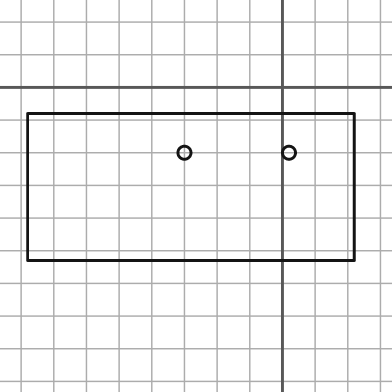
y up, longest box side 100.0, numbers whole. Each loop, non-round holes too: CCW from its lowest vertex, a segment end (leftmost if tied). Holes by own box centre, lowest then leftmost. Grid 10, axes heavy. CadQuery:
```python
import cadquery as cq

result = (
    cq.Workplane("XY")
    .moveTo(-78.0, -53.0)
    .lineTo(22.0, -53.0)
    .lineTo(22.0, -8.0)
    .lineTo(-78.0, -8.0)
    .close()
    .moveTo(-30.0, -20.0)
    .circle(2.0)
    .moveTo(2.0, -20.0)
    .circle(2.0)
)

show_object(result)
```